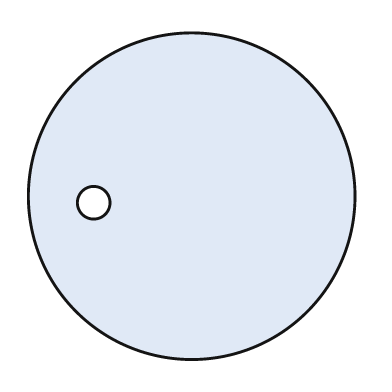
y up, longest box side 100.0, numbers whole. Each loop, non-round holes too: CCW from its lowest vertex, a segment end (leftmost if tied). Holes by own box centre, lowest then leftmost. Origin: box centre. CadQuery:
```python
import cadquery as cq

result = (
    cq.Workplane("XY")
    .moveTo(0.0, 0.0)
    .circle(50.0)
    .moveTo(-30.0, -2.0)
    .circle(5.0)
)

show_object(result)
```